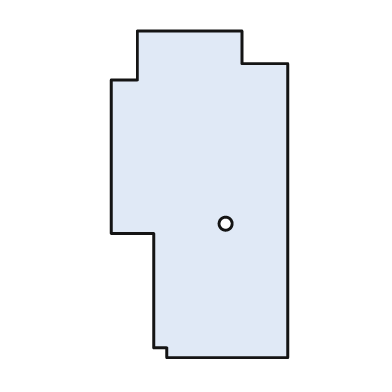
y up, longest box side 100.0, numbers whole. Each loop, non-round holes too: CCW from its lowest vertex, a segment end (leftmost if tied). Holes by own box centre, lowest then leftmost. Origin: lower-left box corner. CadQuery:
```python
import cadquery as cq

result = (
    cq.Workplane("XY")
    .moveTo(17.0, 0.0)
    .lineTo(54.0, 0.0)
    .lineTo(54.0, 90.0)
    .lineTo(40.0, 90.0)
    .lineTo(40.0, 100.0)
    .lineTo(8.0, 100.0)
    .lineTo(8.0, 85.0)
    .lineTo(0.0, 85.0)
    .lineTo(0.0, 38.0)
    .lineTo(13.0, 38.0)
    .lineTo(13.0, 3.0)
    .lineTo(17.0, 3.0)
    .close()
    .moveTo(35.0, 41.0)
    .circle(2.0)
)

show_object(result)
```